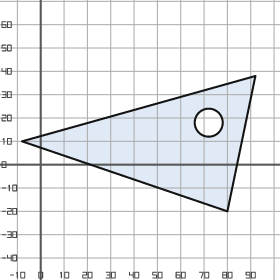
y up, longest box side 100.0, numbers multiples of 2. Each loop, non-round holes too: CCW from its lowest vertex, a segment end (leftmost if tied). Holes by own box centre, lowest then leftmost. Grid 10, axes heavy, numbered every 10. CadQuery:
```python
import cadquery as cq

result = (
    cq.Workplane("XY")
    .moveTo(80.0, -20.0)
    .lineTo(92.0, 38.0)
    .lineTo(-8.0, 10.0)
    .close()
    .moveTo(72.0, 18.0)
    .circle(6.0)
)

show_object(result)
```